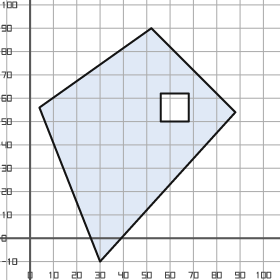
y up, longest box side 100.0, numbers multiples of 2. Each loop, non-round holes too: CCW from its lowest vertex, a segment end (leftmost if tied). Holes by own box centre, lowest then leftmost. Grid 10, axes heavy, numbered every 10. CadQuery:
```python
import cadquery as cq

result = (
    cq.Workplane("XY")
    .moveTo(30.0, -10.0)
    .lineTo(88.0, 54.0)
    .lineTo(52.0, 90.0)
    .lineTo(4.0, 56.0)
    .close()
    .moveTo(56.0, 50.0)
    .lineTo(68.0, 50.0)
    .lineTo(68.0, 62.0)
    .lineTo(56.0, 62.0)
    .close()
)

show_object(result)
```